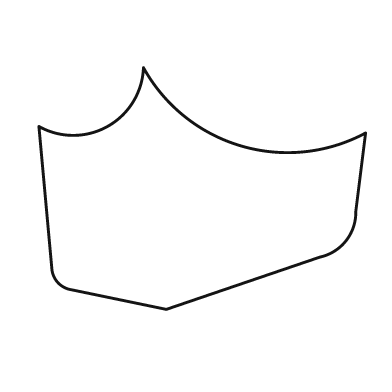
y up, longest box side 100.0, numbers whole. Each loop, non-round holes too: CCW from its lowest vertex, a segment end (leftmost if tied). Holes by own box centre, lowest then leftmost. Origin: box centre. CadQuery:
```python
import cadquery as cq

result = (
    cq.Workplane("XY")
    .moveTo(-11.0, -37.0)
    .lineTo(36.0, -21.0)
    .threePointArc((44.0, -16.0), (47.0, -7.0))
    .lineTo(50.0, 17.0)
    .threePointArc((12.0, 13.0), (-18.0, 37.0))
    .threePointArc((-29.0, 19.0), (-50.0, 19.0))
    .lineTo(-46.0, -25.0)
    .threePointArc((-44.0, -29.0), (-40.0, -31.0))
    .close()
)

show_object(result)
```